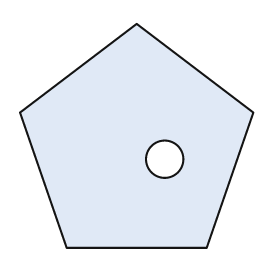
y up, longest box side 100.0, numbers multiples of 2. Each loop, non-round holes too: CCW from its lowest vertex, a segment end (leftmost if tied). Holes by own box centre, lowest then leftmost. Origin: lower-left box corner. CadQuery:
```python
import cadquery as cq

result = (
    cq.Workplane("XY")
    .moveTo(20.0, 0.0)
    .lineTo(80.0, 0.0)
    .lineTo(100.0, 58.0)
    .lineTo(50.0, 96.0)
    .lineTo(0.0, 58.0)
    .close()
    .moveTo(62.0, 38.0)
    .circle(8.0)
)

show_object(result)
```